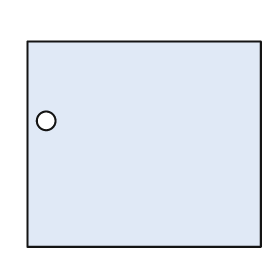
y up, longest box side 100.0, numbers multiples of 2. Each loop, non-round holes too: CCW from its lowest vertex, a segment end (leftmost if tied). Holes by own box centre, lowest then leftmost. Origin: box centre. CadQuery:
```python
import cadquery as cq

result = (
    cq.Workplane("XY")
    .moveTo(-50.0, -44.0)
    .lineTo(50.0, -44.0)
    .lineTo(50.0, 44.0)
    .lineTo(-50.0, 44.0)
    .close()
    .moveTo(-42.0, 10.0)
    .circle(4.0)
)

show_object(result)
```